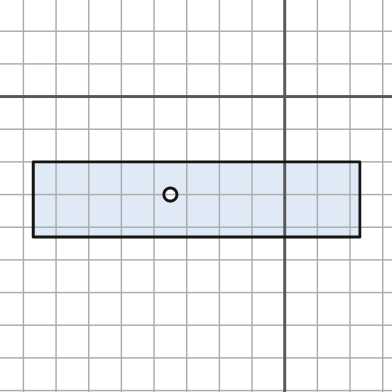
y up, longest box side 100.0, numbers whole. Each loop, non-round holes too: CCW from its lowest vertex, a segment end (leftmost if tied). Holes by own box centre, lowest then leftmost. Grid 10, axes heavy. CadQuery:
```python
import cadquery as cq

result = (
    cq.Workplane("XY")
    .moveTo(-77.0, -43.0)
    .lineTo(23.0, -43.0)
    .lineTo(23.0, -20.0)
    .lineTo(-77.0, -20.0)
    .close()
    .moveTo(-35.0, -30.0)
    .circle(2.0)
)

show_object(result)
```